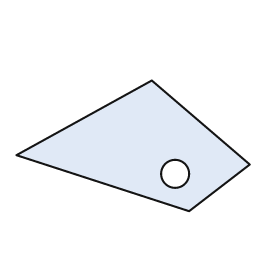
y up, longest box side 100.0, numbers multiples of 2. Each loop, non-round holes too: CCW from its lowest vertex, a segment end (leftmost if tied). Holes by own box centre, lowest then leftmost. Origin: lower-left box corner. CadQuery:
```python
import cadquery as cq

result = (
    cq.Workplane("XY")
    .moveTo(74.0, 0.0)
    .lineTo(100.0, 20.0)
    .lineTo(58.0, 56.0)
    .lineTo(0.0, 24.0)
    .close()
    .moveTo(68.0, 16.0)
    .circle(6.0)
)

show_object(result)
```